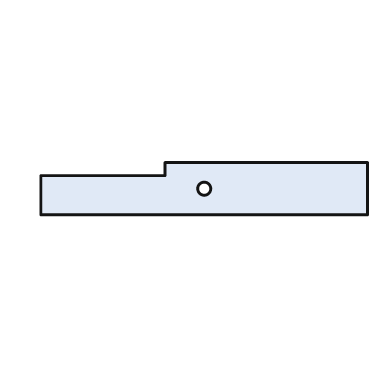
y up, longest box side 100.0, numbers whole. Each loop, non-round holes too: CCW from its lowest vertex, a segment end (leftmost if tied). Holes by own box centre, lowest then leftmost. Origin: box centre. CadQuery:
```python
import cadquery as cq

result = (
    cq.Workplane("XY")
    .moveTo(-50.0, -8.0)
    .lineTo(50.0, -8.0)
    .lineTo(50.0, 8.0)
    .lineTo(-12.0, 8.0)
    .lineTo(-12.0, 4.0)
    .lineTo(-50.0, 4.0)
    .close()
    .moveTo(0.0, 0.0)
    .circle(2.0)
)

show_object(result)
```